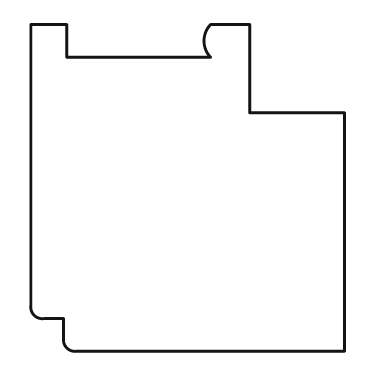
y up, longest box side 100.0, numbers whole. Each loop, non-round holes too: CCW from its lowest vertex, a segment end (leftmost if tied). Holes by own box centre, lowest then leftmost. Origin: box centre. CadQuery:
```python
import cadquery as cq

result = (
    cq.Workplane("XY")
    .moveTo(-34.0, -50.0)
    .lineTo(48.0, -50.0)
    .lineTo(48.0, 23.0)
    .lineTo(19.0, 23.0)
    .lineTo(19.0, 50.0)
    .lineTo(7.0, 50.0)
    .threePointArc((5.0, 45.0), (7.0, 40.0))
    .lineTo(-37.0, 40.0)
    .lineTo(-37.0, 50.0)
    .lineTo(-48.0, 50.0)
    .lineTo(-48.0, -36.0)
    .threePointArc((-47.0, -39.0), (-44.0, -40.0))
    .lineTo(-38.0, -40.0)
    .lineTo(-38.0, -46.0)
    .threePointArc((-37.0, -49.0), (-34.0, -50.0))
    .close()
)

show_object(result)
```